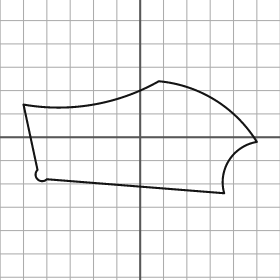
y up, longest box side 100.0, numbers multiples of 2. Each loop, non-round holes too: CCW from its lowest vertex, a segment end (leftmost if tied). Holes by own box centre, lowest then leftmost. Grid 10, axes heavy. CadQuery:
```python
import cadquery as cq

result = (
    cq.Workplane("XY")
    .moveTo(36.0, -24.0)
    .threePointArc((38.0, -10.0), (50.0, -2.0))
    .threePointArc((32.0, 16.0), (8.0, 24.0))
    .threePointArc((-20.0, 14.0), (-50.0, 14.0))
    .lineTo(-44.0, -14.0)
    .threePointArc((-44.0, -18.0), (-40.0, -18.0))
    .close()
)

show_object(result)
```